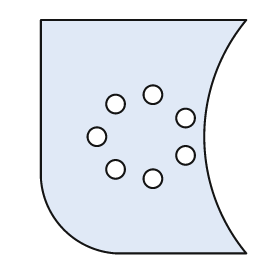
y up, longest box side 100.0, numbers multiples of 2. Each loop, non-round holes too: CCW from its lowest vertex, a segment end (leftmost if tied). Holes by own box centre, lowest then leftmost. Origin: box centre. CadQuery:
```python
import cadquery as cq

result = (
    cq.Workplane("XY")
    .moveTo(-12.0, -50.0)
    .lineTo(44.0, -50.0)
    .threePointArc((26.0, 0.0), (44.0, 50.0))
    .lineTo(-44.0, 50.0)
    .lineTo(-44.0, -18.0)
    .threePointArc((-34.0, -40.0), (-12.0, -50.0))
    .close()
    .moveTo(4.0, -18.0)
    .circle(4.0)
    .moveTo(-12.0, -14.0)
    .circle(4.0)
    .moveTo(18.0, -8.0)
    .circle(4.0)
    .moveTo(-20.0, 0.0)
    .circle(4.0)
    .moveTo(18.0, 8.0)
    .circle(4.0)
    .moveTo(-12.0, 14.0)
    .circle(4.0)
    .moveTo(4.0, 18.0)
    .circle(4.0)
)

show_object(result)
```